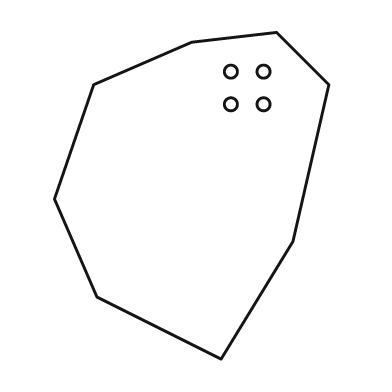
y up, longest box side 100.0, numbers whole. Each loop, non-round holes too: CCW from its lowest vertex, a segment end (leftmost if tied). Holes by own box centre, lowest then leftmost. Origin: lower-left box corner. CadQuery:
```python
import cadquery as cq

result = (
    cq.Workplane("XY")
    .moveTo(51.0, 0.0)
    .lineTo(73.0, 36.0)
    .lineTo(84.0, 84.0)
    .lineTo(68.0, 100.0)
    .lineTo(42.0, 97.0)
    .lineTo(12.0, 84.0)
    .lineTo(0.0, 49.0)
    .lineTo(13.0, 19.0)
    .close()
    .moveTo(54.0, 78.0)
    .circle(2.0)
    .moveTo(64.0, 78.0)
    .circle(2.0)
    .moveTo(54.0, 88.0)
    .circle(2.0)
    .moveTo(64.0, 88.0)
    .circle(2.0)
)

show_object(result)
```